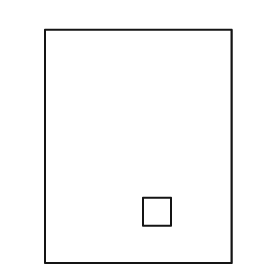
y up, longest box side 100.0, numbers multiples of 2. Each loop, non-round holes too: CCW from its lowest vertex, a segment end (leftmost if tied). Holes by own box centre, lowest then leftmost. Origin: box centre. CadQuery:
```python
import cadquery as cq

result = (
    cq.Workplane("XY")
    .moveTo(-40.0, -50.0)
    .lineTo(40.0, -50.0)
    .lineTo(40.0, 50.0)
    .lineTo(-40.0, 50.0)
    .close()
    .moveTo(2.0, -34.0)
    .lineTo(14.0, -34.0)
    .lineTo(14.0, -22.0)
    .lineTo(2.0, -22.0)
    .close()
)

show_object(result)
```